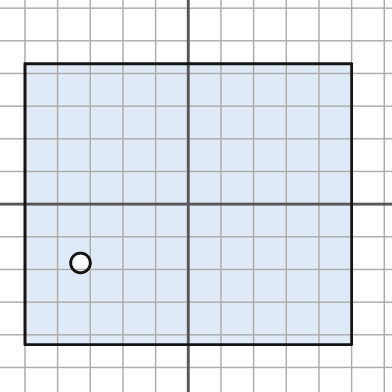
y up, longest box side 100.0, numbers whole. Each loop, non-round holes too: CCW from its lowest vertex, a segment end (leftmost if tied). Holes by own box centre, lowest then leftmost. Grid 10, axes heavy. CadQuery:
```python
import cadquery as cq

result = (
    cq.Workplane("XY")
    .moveTo(-50.0, -43.0)
    .lineTo(50.0, -43.0)
    .lineTo(50.0, 43.0)
    .lineTo(-50.0, 43.0)
    .close()
    .moveTo(-33.0, -18.0)
    .circle(3.0)
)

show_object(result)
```